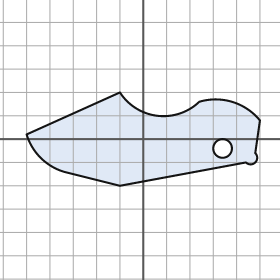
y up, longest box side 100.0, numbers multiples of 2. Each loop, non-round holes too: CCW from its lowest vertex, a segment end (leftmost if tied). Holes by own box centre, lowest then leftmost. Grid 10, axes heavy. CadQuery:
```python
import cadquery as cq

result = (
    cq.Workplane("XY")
    .moveTo(-10.0, -20.0)
    .lineTo(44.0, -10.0)
    .threePointArc((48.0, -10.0), (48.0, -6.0))
    .lineTo(50.0, 8.0)
    .threePointArc((38.0, 16.0), (24.0, 16.0))
    .threePointArc((6.0, 10.0), (-10.0, 20.0))
    .lineTo(-50.0, 2.0)
    .threePointArc((-44.0, -8.0), (-34.0, -14.0))
    .close()
    .moveTo(34.0, -4.0)
    .circle(4.0)
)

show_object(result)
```